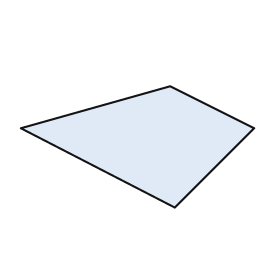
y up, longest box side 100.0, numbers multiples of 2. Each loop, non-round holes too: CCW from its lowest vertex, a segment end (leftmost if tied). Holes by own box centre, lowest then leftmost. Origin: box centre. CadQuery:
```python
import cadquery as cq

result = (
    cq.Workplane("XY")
    .moveTo(16.0, -26.0)
    .lineTo(50.0, 8.0)
    .lineTo(14.0, 26.0)
    .lineTo(-50.0, 8.0)
    .close()
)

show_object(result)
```